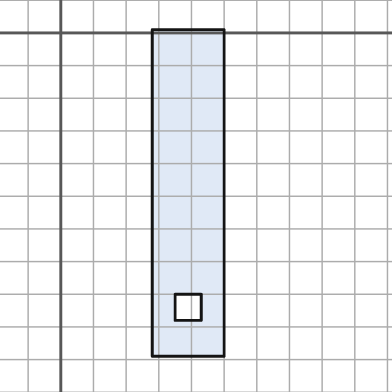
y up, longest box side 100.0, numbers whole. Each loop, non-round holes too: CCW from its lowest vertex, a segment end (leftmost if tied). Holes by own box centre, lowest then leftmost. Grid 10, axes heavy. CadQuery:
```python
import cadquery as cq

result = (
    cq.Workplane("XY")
    .moveTo(28.0, -99.0)
    .lineTo(50.0, -99.0)
    .lineTo(50.0, 1.0)
    .lineTo(28.0, 1.0)
    .close()
    .moveTo(35.0, -88.0)
    .lineTo(43.0, -88.0)
    .lineTo(43.0, -80.0)
    .lineTo(35.0, -80.0)
    .close()
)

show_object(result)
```